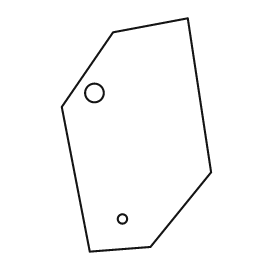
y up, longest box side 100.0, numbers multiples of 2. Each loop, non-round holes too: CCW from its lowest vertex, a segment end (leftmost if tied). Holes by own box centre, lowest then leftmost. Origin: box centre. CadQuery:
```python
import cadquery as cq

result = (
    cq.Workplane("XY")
    .moveTo(-20.0, -50.0)
    .lineTo(6.0, -48.0)
    .lineTo(32.0, -16.0)
    .lineTo(22.0, 50.0)
    .lineTo(-10.0, 44.0)
    .lineTo(-32.0, 12.0)
    .close()
    .moveTo(-6.0, -36.0)
    .circle(2.0)
    .moveTo(-18.0, 18.0)
    .circle(4.0)
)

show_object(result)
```